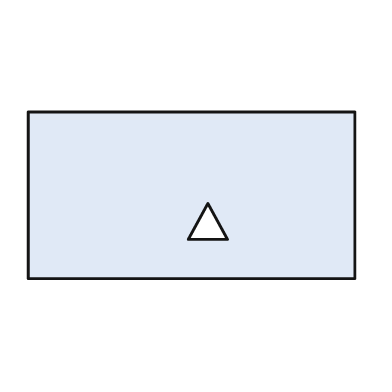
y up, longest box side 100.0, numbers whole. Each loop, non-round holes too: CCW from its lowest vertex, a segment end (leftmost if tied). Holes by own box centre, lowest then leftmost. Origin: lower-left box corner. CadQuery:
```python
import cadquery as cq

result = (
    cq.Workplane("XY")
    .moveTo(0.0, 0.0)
    .lineTo(100.0, 0.0)
    .lineTo(100.0, 51.0)
    .lineTo(0.0, 51.0)
    .close()
    .moveTo(49.0, 12.0)
    .lineTo(61.0, 12.0)
    .lineTo(55.0, 23.0)
    .close()
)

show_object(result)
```